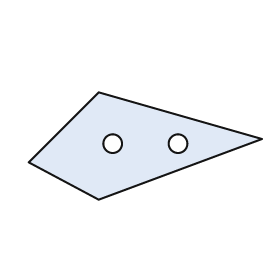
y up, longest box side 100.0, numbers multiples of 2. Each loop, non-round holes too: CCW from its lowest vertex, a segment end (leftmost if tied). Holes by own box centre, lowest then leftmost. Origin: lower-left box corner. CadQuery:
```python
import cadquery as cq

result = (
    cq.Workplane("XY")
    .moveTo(30.0, 0.0)
    .lineTo(100.0, 26.0)
    .lineTo(30.0, 46.0)
    .lineTo(0.0, 16.0)
    .close()
    .moveTo(36.0, 24.0)
    .circle(4.0)
    .moveTo(64.0, 24.0)
    .circle(4.0)
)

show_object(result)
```